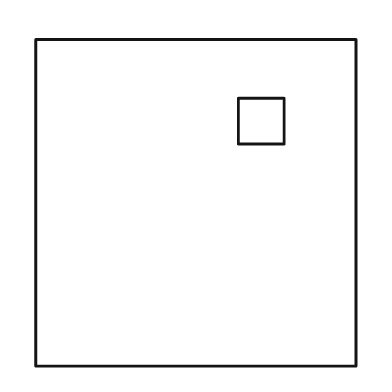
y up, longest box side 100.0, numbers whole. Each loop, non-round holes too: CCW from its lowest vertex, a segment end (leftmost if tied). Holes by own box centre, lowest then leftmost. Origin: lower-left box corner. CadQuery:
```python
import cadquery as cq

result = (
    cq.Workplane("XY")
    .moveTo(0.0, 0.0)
    .lineTo(98.0, 0.0)
    .lineTo(98.0, 100.0)
    .lineTo(0.0, 100.0)
    .close()
    .moveTo(62.0, 68.0)
    .lineTo(76.0, 68.0)
    .lineTo(76.0, 82.0)
    .lineTo(62.0, 82.0)
    .close()
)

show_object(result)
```